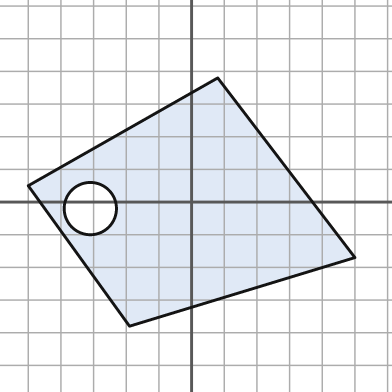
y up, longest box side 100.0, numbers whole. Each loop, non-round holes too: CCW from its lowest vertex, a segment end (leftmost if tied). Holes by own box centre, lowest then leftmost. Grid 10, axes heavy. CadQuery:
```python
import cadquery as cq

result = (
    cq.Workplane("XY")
    .moveTo(-19.0, -38.0)
    .lineTo(50.0, -17.0)
    .lineTo(8.0, 38.0)
    .lineTo(-50.0, 5.0)
    .close()
    .moveTo(-31.0, -2.0)
    .circle(8.0)
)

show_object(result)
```